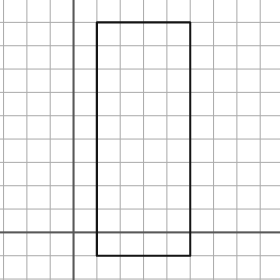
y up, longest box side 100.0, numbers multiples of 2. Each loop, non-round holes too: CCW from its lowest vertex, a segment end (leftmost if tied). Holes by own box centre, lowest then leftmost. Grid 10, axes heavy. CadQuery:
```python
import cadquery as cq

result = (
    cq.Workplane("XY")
    .moveTo(10.0, -10.0)
    .lineTo(50.0, -10.0)
    .lineTo(50.0, 90.0)
    .lineTo(10.0, 90.0)
    .close()
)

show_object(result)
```